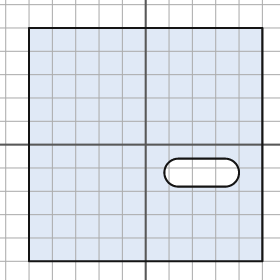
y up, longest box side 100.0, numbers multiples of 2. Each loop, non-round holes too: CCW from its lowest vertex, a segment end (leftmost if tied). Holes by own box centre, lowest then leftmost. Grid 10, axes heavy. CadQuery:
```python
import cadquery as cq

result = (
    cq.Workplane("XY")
    .moveTo(-50.0, -50.0)
    .lineTo(50.0, -50.0)
    .lineTo(50.0, 50.0)
    .lineTo(-50.0, 50.0)
    .close()
    .moveTo(14.0, -18.0)
    .lineTo(34.0, -18.0)
    .threePointArc((40.0, -12.0), (34.0, -6.0))
    .lineTo(14.0, -6.0)
    .threePointArc((8.0, -12.0), (14.0, -18.0))
    .close()
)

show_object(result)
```